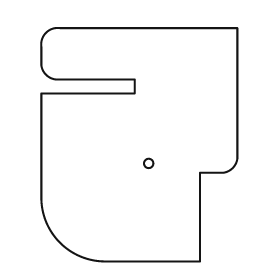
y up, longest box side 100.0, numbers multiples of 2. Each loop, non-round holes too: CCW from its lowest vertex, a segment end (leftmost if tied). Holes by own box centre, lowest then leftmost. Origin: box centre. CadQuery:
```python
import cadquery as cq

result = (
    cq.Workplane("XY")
    .moveTo(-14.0, -50.0)
    .lineTo(26.0, -50.0)
    .lineTo(26.0, -12.0)
    .lineTo(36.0, -12.0)
    .threePointArc((40.0, -10.0), (42.0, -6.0))
    .lineTo(42.0, 50.0)
    .lineTo(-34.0, 50.0)
    .threePointArc((-40.0, 48.0), (-42.0, 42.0))
    .lineTo(-42.0, 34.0)
    .threePointArc((-40.0, 30.0), (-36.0, 28.0))
    .lineTo(-2.0, 28.0)
    .lineTo(-2.0, 22.0)
    .lineTo(-42.0, 22.0)
    .lineTo(-42.0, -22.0)
    .threePointArc((-34.0, -42.0), (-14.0, -50.0))
    .close()
    .moveTo(4.0, -8.0)
    .circle(2.0)
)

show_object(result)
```